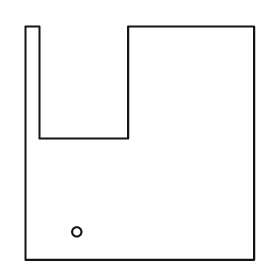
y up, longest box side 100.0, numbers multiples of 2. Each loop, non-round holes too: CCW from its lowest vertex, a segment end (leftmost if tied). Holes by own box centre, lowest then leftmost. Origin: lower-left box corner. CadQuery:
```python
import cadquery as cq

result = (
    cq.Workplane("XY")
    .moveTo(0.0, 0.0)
    .lineTo(98.0, 0.0)
    .lineTo(98.0, 100.0)
    .lineTo(44.0, 100.0)
    .lineTo(44.0, 52.0)
    .lineTo(6.0, 52.0)
    .lineTo(6.0, 100.0)
    .lineTo(0.0, 100.0)
    .close()
    .moveTo(22.0, 12.0)
    .circle(2.0)
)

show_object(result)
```